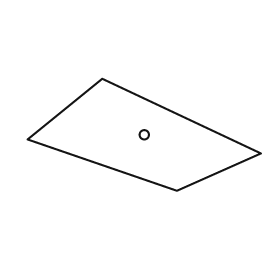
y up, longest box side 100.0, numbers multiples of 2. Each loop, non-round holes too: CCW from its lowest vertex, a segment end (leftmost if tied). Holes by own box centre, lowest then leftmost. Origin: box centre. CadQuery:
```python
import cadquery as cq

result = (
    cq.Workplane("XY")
    .moveTo(14.0, -24.0)
    .lineTo(50.0, -8.0)
    .lineTo(-18.0, 24.0)
    .lineTo(-50.0, -2.0)
    .close()
    .moveTo(0.0, 0.0)
    .circle(2.0)
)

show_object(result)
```